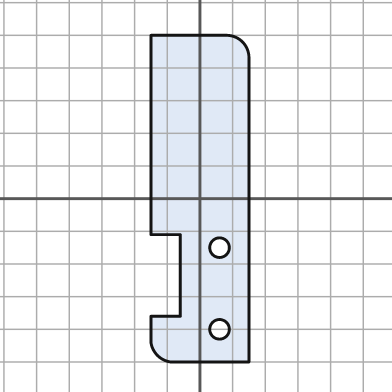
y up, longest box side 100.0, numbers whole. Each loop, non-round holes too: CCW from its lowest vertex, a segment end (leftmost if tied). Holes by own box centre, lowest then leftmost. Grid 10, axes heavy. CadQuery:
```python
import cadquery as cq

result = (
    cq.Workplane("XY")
    .moveTo(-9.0, -50.0)
    .lineTo(15.0, -50.0)
    .lineTo(15.0, 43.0)
    .threePointArc((13.0, 48.0), (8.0, 50.0))
    .lineTo(-15.0, 50.0)
    .lineTo(-15.0, -11.0)
    .lineTo(-6.0, -11.0)
    .lineTo(-6.0, -36.0)
    .lineTo(-15.0, -36.0)
    .lineTo(-15.0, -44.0)
    .threePointArc((-13.0, -48.0), (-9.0, -50.0))
    .close()
    .moveTo(6.0, -40.0)
    .circle(3.0)
    .moveTo(6.0, -15.0)
    .circle(3.0)
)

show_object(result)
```